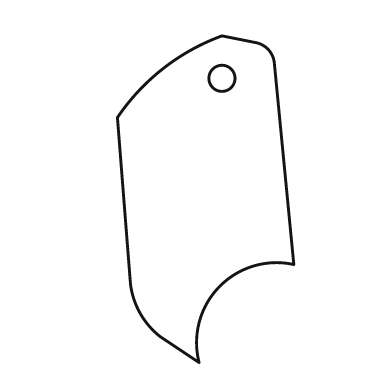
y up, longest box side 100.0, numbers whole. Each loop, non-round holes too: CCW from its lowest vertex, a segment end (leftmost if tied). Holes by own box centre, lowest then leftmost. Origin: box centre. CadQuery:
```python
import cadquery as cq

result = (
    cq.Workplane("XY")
    .moveTo(-2.0, -50.0)
    .threePointArc((4.0, -27.0), (27.0, -20.0))
    .lineTo(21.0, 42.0)
    .threePointArc((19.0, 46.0), (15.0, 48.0))
    .lineTo(5.0, 50.0)
    .threePointArc((-13.0, 40.0), (-27.0, 25.0))
    .lineTo(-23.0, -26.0)
    .threePointArc((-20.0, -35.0), (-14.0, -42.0))
    .close()
    .moveTo(5.0, 37.0)
    .circle(4.0)
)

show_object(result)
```